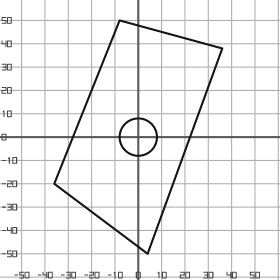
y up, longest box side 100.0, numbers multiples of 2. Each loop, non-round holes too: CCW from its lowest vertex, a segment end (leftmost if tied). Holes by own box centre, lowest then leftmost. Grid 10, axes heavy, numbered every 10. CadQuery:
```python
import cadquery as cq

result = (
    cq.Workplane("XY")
    .moveTo(4.0, -50.0)
    .lineTo(36.0, 38.0)
    .lineTo(-8.0, 50.0)
    .lineTo(-36.0, -20.0)
    .close()
    .moveTo(0.0, 0.0)
    .circle(8.0)
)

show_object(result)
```